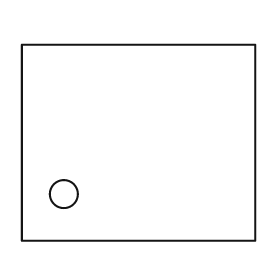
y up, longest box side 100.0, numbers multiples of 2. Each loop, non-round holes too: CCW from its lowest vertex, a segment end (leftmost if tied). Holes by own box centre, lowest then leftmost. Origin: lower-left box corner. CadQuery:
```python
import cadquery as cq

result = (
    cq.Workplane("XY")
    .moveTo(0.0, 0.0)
    .lineTo(100.0, 0.0)
    .lineTo(100.0, 84.0)
    .lineTo(0.0, 84.0)
    .close()
    .moveTo(18.0, 20.0)
    .circle(6.0)
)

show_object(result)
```